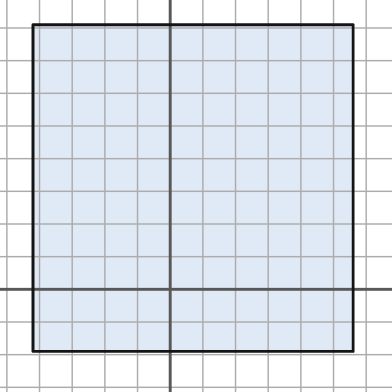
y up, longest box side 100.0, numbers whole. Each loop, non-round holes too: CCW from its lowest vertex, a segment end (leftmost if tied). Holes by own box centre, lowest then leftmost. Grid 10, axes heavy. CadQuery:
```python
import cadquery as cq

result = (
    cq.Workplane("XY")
    .moveTo(-42.0, -19.0)
    .lineTo(56.0, -19.0)
    .lineTo(56.0, 81.0)
    .lineTo(-42.0, 81.0)
    .close()
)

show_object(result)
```